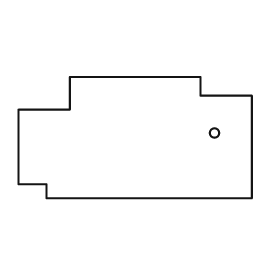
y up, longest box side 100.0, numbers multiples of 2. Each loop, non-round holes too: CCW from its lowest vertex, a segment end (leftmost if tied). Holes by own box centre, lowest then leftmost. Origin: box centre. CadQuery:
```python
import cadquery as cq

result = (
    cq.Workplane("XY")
    .moveTo(-38.0, -26.0)
    .lineTo(50.0, -26.0)
    .lineTo(50.0, 18.0)
    .lineTo(28.0, 18.0)
    .lineTo(28.0, 26.0)
    .lineTo(-28.0, 26.0)
    .lineTo(-28.0, 12.0)
    .lineTo(-50.0, 12.0)
    .lineTo(-50.0, -20.0)
    .lineTo(-38.0, -20.0)
    .close()
    .moveTo(34.0, 2.0)
    .circle(2.0)
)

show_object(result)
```